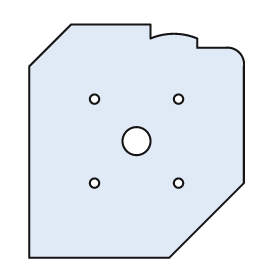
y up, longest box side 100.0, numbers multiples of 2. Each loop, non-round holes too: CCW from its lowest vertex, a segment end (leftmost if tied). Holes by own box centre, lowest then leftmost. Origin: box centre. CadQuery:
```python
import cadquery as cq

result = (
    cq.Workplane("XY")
    .moveTo(-46.0, -50.0)
    .lineTo(14.0, -50.0)
    .lineTo(46.0, -18.0)
    .lineTo(46.0, 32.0)
    .threePointArc((44.0, 38.0), (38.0, 40.0))
    .lineTo(26.0, 40.0)
    .lineTo(26.0, 44.0)
    .threePointArc((16.0, 46.0), (6.0, 44.0))
    .lineTo(6.0, 50.0)
    .lineTo(-28.0, 50.0)
    .lineTo(-46.0, 32.0)
    .close()
    .moveTo(-18.0, -18.0)
    .circle(2.0)
    .moveTo(18.0, -18.0)
    .circle(2.0)
    .moveTo(0.0, 0.0)
    .circle(6.0)
    .moveTo(-18.0, 18.0)
    .circle(2.0)
    .moveTo(18.0, 18.0)
    .circle(2.0)
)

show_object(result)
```